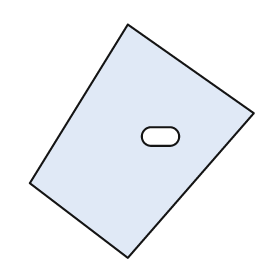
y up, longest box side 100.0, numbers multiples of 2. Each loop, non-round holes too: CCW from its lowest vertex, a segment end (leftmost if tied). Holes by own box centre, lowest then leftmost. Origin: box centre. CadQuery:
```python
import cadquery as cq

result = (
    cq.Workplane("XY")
    .moveTo(-6.0, -50.0)
    .lineTo(48.0, 12.0)
    .lineTo(-6.0, 50.0)
    .lineTo(-48.0, -18.0)
    .close()
    .moveTo(4.0, -2.0)
    .lineTo(12.0, -2.0)
    .threePointArc((16.0, 2.0), (12.0, 6.0))
    .lineTo(4.0, 6.0)
    .threePointArc((0.0, 2.0), (4.0, -2.0))
    .close()
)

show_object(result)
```